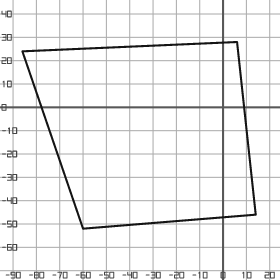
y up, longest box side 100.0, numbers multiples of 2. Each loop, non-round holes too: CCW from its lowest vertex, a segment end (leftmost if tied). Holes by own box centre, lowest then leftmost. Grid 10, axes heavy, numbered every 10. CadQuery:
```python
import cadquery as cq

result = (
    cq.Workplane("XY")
    .moveTo(-60.0, -52.0)
    .lineTo(14.0, -46.0)
    .lineTo(6.0, 28.0)
    .lineTo(-86.0, 24.0)
    .close()
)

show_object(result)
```